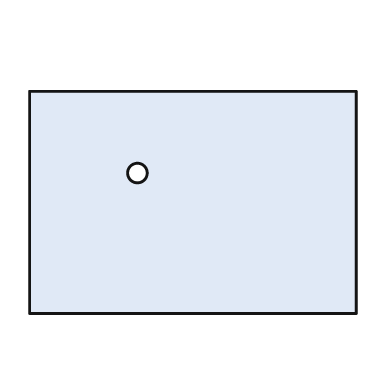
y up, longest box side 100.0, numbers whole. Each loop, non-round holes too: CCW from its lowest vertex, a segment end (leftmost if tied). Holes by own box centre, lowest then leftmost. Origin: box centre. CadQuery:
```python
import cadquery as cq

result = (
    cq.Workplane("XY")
    .moveTo(-50.0, -34.0)
    .lineTo(50.0, -34.0)
    .lineTo(50.0, 34.0)
    .lineTo(-50.0, 34.0)
    .close()
    .moveTo(-17.0, 9.0)
    .circle(3.0)
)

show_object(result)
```